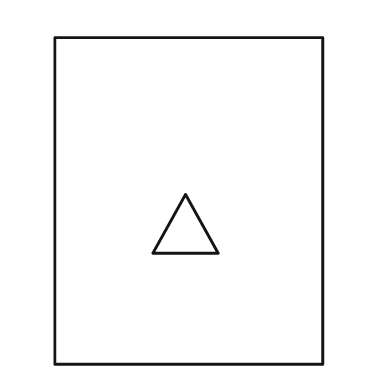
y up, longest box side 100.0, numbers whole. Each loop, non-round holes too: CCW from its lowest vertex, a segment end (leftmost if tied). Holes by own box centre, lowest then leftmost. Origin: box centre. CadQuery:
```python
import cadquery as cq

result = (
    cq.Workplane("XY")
    .moveTo(-41.0, -50.0)
    .lineTo(41.0, -50.0)
    .lineTo(41.0, 50.0)
    .lineTo(-41.0, 50.0)
    .close()
    .moveTo(-11.0, -16.0)
    .lineTo(9.0, -16.0)
    .lineTo(-1.0, 2.0)
    .close()
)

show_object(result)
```